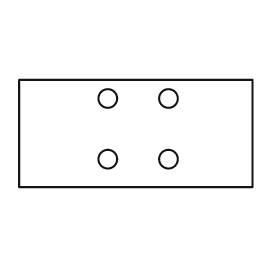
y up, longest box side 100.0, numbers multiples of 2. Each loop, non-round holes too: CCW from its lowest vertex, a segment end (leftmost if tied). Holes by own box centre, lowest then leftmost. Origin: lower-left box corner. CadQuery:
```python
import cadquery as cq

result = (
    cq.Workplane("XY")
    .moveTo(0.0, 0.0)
    .lineTo(100.0, 0.0)
    .lineTo(100.0, 46.0)
    .lineTo(0.0, 46.0)
    .close()
    .moveTo(38.0, 12.0)
    .circle(4.0)
    .moveTo(64.0, 12.0)
    .circle(4.0)
    .moveTo(38.0, 38.0)
    .circle(4.0)
    .moveTo(64.0, 38.0)
    .circle(4.0)
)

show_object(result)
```